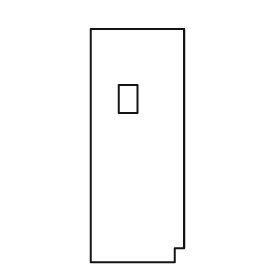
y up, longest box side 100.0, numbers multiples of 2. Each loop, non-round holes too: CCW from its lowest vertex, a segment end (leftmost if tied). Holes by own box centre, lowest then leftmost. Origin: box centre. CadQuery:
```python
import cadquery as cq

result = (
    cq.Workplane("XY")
    .moveTo(-20.0, -50.0)
    .lineTo(16.0, -50.0)
    .lineTo(16.0, -44.0)
    .lineTo(20.0, -44.0)
    .lineTo(20.0, 50.0)
    .lineTo(-20.0, 50.0)
    .close()
    .moveTo(-8.0, 14.0)
    .lineTo(0.0, 14.0)
    .lineTo(0.0, 26.0)
    .lineTo(-8.0, 26.0)
    .close()
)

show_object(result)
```